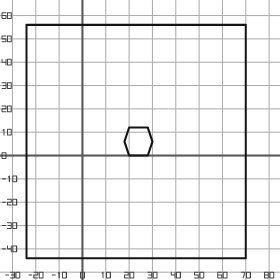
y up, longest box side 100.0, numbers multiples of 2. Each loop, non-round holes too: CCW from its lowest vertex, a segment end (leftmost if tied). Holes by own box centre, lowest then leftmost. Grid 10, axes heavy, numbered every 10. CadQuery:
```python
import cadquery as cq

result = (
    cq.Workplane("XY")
    .moveTo(-24.0, -44.0)
    .lineTo(70.0, -44.0)
    .lineTo(70.0, 56.0)
    .lineTo(-24.0, 56.0)
    .close()
    .moveTo(20.0, 0.0)
    .lineTo(28.0, 0.0)
    .lineTo(30.0, 6.0)
    .lineTo(28.0, 12.0)
    .lineTo(20.0, 12.0)
    .lineTo(18.0, 6.0)
    .close()
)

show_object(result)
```